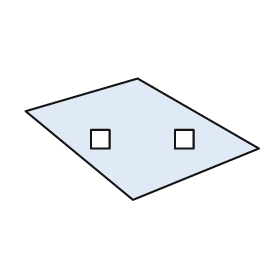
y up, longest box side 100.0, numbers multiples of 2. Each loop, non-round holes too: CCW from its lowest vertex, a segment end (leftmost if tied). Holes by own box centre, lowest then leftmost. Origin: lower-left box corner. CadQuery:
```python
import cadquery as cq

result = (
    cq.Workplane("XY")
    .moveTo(46.0, 0.0)
    .lineTo(100.0, 22.0)
    .lineTo(48.0, 52.0)
    .lineTo(0.0, 38.0)
    .close()
    .moveTo(28.0, 22.0)
    .lineTo(36.0, 22.0)
    .lineTo(36.0, 30.0)
    .lineTo(28.0, 30.0)
    .close()
    .moveTo(64.0, 22.0)
    .lineTo(72.0, 22.0)
    .lineTo(72.0, 30.0)
    .lineTo(64.0, 30.0)
    .close()
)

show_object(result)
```